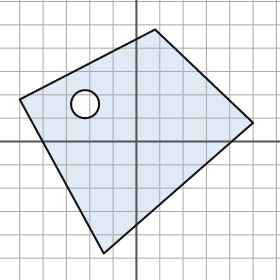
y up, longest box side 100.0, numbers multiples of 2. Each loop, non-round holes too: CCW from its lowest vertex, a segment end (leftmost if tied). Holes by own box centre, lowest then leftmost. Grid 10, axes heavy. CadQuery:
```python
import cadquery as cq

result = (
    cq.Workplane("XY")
    .moveTo(-14.0, -48.0)
    .lineTo(50.0, 8.0)
    .lineTo(8.0, 48.0)
    .lineTo(-50.0, 18.0)
    .close()
    .moveTo(-22.0, 16.0)
    .circle(6.0)
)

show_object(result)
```